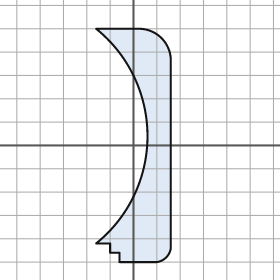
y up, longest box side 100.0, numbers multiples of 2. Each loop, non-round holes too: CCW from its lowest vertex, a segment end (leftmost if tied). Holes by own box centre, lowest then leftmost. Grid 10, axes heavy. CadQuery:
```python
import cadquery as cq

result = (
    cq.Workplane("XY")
    .moveTo(-6.0, -50.0)
    .lineTo(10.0, -50.0)
    .threePointArc((14.0, -48.0), (16.0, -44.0))
    .lineTo(16.0, 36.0)
    .threePointArc((12.0, 46.0), (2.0, 50.0))
    .lineTo(-16.0, 50.0)
    .threePointArc((6.0, 4.0), (-16.0, -42.0))
    .lineTo(-10.0, -42.0)
    .lineTo(-10.0, -46.0)
    .lineTo(-6.0, -46.0)
    .close()
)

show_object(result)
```